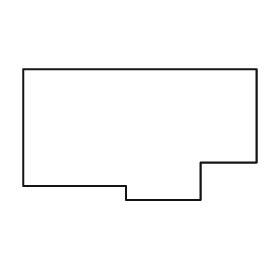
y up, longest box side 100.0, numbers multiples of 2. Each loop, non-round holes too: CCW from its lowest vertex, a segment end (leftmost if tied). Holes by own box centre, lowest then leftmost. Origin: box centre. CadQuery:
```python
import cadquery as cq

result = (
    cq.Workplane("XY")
    .moveTo(-6.0, -28.0)
    .lineTo(26.0, -28.0)
    .lineTo(26.0, -12.0)
    .lineTo(50.0, -12.0)
    .lineTo(50.0, 28.0)
    .lineTo(-50.0, 28.0)
    .lineTo(-50.0, -22.0)
    .lineTo(-6.0, -22.0)
    .close()
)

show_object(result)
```